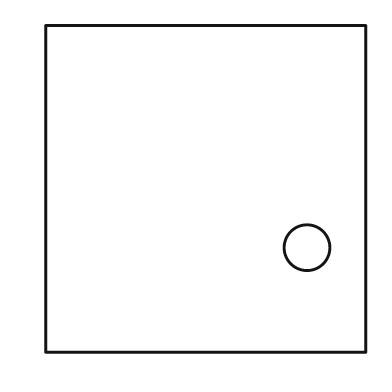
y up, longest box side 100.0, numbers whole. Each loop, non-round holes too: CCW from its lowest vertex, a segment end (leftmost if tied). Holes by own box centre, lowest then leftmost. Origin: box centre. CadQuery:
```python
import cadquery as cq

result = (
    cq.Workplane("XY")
    .moveTo(-49.0, -50.0)
    .lineTo(49.0, -50.0)
    .lineTo(49.0, 50.0)
    .lineTo(-49.0, 50.0)
    .close()
    .moveTo(31.0, -18.0)
    .circle(7.0)
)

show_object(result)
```